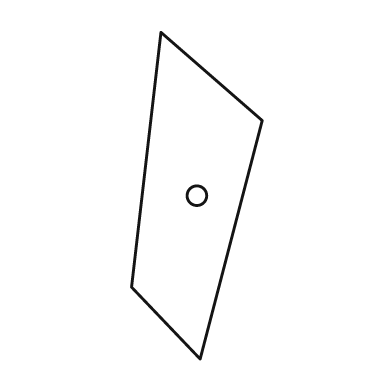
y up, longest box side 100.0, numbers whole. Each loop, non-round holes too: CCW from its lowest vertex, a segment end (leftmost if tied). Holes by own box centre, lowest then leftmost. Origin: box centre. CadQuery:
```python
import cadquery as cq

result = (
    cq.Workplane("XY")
    .moveTo(1.0, -50.0)
    .lineTo(20.0, 23.0)
    .lineTo(-11.0, 50.0)
    .lineTo(-20.0, -28.0)
    .close()
    .moveTo(0.0, 0.0)
    .circle(3.0)
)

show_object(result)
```